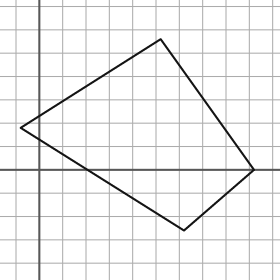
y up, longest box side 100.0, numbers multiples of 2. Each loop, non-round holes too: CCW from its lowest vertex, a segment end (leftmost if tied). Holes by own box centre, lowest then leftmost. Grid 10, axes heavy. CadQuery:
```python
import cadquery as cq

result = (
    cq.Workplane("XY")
    .moveTo(62.0, -26.0)
    .lineTo(92.0, 0.0)
    .lineTo(52.0, 56.0)
    .lineTo(-8.0, 18.0)
    .close()
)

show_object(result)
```